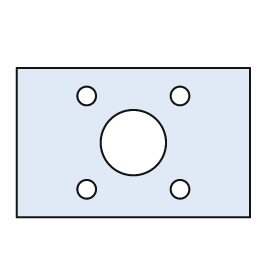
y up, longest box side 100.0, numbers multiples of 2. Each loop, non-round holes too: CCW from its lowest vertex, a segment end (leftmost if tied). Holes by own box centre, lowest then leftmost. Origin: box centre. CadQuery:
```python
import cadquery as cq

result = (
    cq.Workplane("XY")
    .moveTo(-50.0, -32.0)
    .lineTo(50.0, -32.0)
    .lineTo(50.0, 32.0)
    .lineTo(-50.0, 32.0)
    .close()
    .moveTo(-20.0, -20.0)
    .circle(4.0)
    .moveTo(20.0, -20.0)
    .circle(4.0)
    .moveTo(0.0, 0.0)
    .circle(14.0)
    .moveTo(-20.0, 20.0)
    .circle(4.0)
    .moveTo(20.0, 20.0)
    .circle(4.0)
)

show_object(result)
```